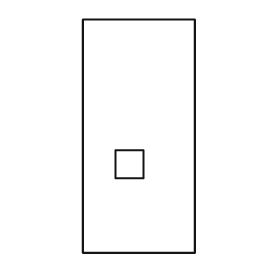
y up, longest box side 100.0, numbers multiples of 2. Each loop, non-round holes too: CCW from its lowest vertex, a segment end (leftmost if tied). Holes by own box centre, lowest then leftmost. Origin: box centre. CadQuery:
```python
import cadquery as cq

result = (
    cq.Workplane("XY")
    .moveTo(-24.0, -50.0)
    .lineTo(24.0, -50.0)
    .lineTo(24.0, 50.0)
    .lineTo(-24.0, 50.0)
    .close()
    .moveTo(-10.0, -18.0)
    .lineTo(2.0, -18.0)
    .lineTo(2.0, -6.0)
    .lineTo(-10.0, -6.0)
    .close()
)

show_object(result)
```